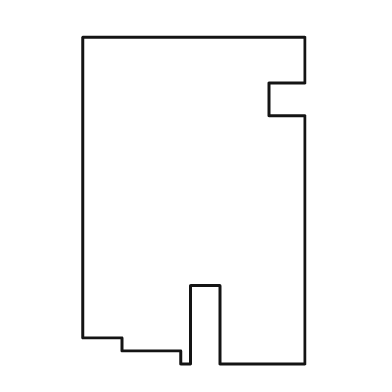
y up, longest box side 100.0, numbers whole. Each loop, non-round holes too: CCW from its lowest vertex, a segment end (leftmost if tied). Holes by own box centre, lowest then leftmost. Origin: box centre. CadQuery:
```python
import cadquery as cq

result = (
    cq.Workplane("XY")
    .moveTo(-4.0, -50.0)
    .lineTo(-1.0, -50.0)
    .lineTo(-1.0, -26.0)
    .lineTo(8.0, -26.0)
    .lineTo(8.0, -50.0)
    .lineTo(34.0, -50.0)
    .lineTo(34.0, 26.0)
    .lineTo(23.0, 26.0)
    .lineTo(23.0, 36.0)
    .lineTo(34.0, 36.0)
    .lineTo(34.0, 50.0)
    .lineTo(-34.0, 50.0)
    .lineTo(-34.0, -42.0)
    .lineTo(-22.0, -42.0)
    .lineTo(-22.0, -46.0)
    .lineTo(-4.0, -46.0)
    .close()
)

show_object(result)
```